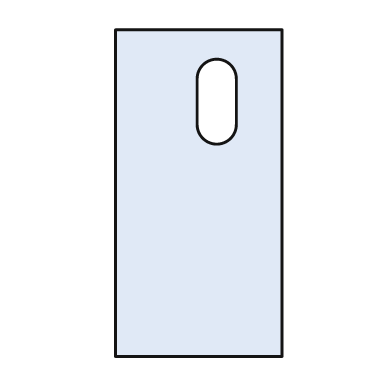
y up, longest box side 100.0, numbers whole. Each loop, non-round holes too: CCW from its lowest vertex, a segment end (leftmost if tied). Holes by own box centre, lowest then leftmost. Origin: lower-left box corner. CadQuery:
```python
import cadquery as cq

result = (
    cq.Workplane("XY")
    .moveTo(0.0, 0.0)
    .lineTo(51.0, 0.0)
    .lineTo(51.0, 100.0)
    .lineTo(0.0, 100.0)
    .close()
    .moveTo(25.0, 71.0)
    .threePointArc((31.0, 65.0), (37.0, 71.0))
    .lineTo(37.0, 85.0)
    .threePointArc((31.0, 91.0), (25.0, 85.0))
    .close()
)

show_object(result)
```